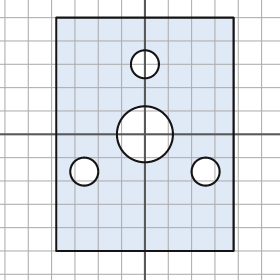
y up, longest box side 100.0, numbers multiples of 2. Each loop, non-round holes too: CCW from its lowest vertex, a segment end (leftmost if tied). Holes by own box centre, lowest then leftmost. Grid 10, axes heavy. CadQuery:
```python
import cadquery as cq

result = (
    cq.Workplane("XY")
    .moveTo(-38.0, -50.0)
    .lineTo(38.0, -50.0)
    .lineTo(38.0, 50.0)
    .lineTo(-38.0, 50.0)
    .close()
    .moveTo(-26.0, -16.0)
    .circle(6.0)
    .moveTo(26.0, -16.0)
    .circle(6.0)
    .moveTo(0.0, 0.0)
    .circle(12.0)
    .moveTo(0.0, 30.0)
    .circle(6.0)
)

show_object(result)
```